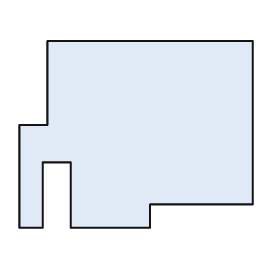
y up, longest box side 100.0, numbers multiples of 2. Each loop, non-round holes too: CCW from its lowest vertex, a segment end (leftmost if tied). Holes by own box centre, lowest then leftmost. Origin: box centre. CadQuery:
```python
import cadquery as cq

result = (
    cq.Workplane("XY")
    .moveTo(-50.0, -40.0)
    .lineTo(-40.0, -40.0)
    .lineTo(-40.0, -12.0)
    .lineTo(-28.0, -12.0)
    .lineTo(-28.0, -40.0)
    .lineTo(6.0, -40.0)
    .lineTo(6.0, -30.0)
    .lineTo(50.0, -30.0)
    .lineTo(50.0, 40.0)
    .lineTo(-38.0, 40.0)
    .lineTo(-38.0, 4.0)
    .lineTo(-50.0, 4.0)
    .close()
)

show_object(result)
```